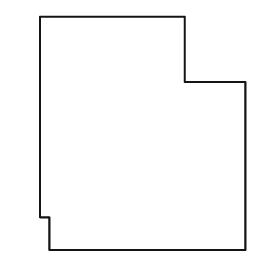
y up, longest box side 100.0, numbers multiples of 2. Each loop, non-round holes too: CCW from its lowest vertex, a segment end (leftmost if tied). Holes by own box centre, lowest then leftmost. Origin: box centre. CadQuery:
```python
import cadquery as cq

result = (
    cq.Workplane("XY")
    .moveTo(-40.0, -50.0)
    .lineTo(44.0, -50.0)
    .lineTo(44.0, 22.0)
    .lineTo(18.0, 22.0)
    .lineTo(18.0, 50.0)
    .lineTo(-44.0, 50.0)
    .lineTo(-44.0, -36.0)
    .lineTo(-40.0, -36.0)
    .close()
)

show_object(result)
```